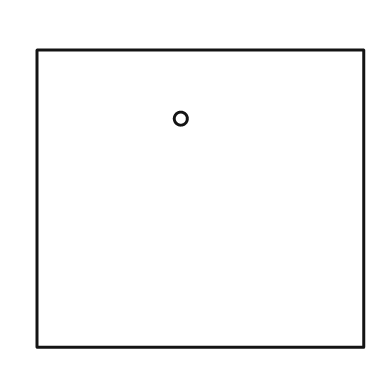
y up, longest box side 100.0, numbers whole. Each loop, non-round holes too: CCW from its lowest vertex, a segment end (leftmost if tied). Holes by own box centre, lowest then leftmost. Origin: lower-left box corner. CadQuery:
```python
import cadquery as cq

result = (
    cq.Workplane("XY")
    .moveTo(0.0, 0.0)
    .lineTo(100.0, 0.0)
    .lineTo(100.0, 91.0)
    .lineTo(0.0, 91.0)
    .close()
    .moveTo(44.0, 70.0)
    .circle(2.0)
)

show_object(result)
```